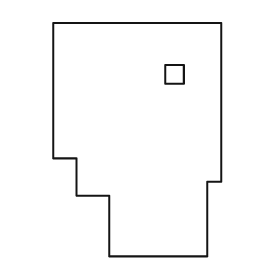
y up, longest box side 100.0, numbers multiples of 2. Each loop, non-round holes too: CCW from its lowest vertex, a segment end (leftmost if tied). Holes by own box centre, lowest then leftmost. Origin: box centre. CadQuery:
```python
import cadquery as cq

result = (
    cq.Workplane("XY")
    .moveTo(-12.0, -50.0)
    .lineTo(30.0, -50.0)
    .lineTo(30.0, -18.0)
    .lineTo(36.0, -18.0)
    .lineTo(36.0, 50.0)
    .lineTo(-36.0, 50.0)
    .lineTo(-36.0, -8.0)
    .lineTo(-26.0, -8.0)
    .lineTo(-26.0, -24.0)
    .lineTo(-12.0, -24.0)
    .close()
    .moveTo(12.0, 24.0)
    .lineTo(20.0, 24.0)
    .lineTo(20.0, 32.0)
    .lineTo(12.0, 32.0)
    .close()
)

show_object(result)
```